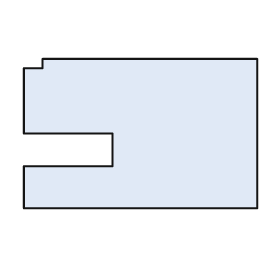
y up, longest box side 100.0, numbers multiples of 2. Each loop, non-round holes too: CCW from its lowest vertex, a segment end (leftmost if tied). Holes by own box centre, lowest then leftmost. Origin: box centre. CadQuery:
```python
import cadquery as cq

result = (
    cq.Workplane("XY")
    .moveTo(-50.0, -32.0)
    .lineTo(50.0, -32.0)
    .lineTo(50.0, 32.0)
    .lineTo(-42.0, 32.0)
    .lineTo(-42.0, 28.0)
    .lineTo(-50.0, 28.0)
    .lineTo(-50.0, 0.0)
    .lineTo(-12.0, 0.0)
    .lineTo(-12.0, -14.0)
    .lineTo(-50.0, -14.0)
    .close()
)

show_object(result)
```